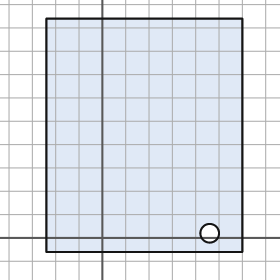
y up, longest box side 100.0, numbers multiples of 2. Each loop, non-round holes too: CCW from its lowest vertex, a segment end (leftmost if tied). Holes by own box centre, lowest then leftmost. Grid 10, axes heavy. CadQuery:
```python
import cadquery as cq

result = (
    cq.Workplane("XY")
    .moveTo(-24.0, -6.0)
    .lineTo(60.0, -6.0)
    .lineTo(60.0, 94.0)
    .lineTo(-24.0, 94.0)
    .close()
    .moveTo(46.0, 2.0)
    .circle(4.0)
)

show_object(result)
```